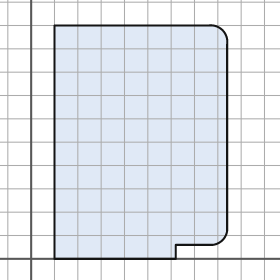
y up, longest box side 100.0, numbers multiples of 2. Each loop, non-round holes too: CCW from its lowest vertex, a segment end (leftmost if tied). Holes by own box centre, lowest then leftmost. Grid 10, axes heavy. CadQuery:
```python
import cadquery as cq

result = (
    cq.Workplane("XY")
    .moveTo(10.0, 0.0)
    .lineTo(62.0, 0.0)
    .lineTo(62.0, 6.0)
    .lineTo(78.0, 6.0)
    .threePointArc((82.0, 8.0), (84.0, 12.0))
    .lineTo(84.0, 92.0)
    .threePointArc((82.0, 98.0), (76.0, 100.0))
    .lineTo(10.0, 100.0)
    .close()
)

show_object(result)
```